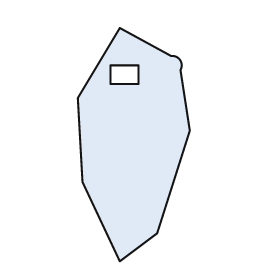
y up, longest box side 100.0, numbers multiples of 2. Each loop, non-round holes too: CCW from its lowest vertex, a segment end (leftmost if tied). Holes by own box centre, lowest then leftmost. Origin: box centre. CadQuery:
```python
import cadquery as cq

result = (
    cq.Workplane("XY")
    .moveTo(-6.0, -50.0)
    .lineTo(10.0, -38.0)
    .lineTo(24.0, 6.0)
    .lineTo(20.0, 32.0)
    .threePointArc((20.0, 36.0), (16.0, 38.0))
    .lineTo(-6.0, 50.0)
    .lineTo(-24.0, 20.0)
    .lineTo(-22.0, -16.0)
    .close()
    .moveTo(-10.0, 26.0)
    .lineTo(2.0, 26.0)
    .lineTo(2.0, 34.0)
    .lineTo(-10.0, 34.0)
    .close()
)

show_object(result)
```